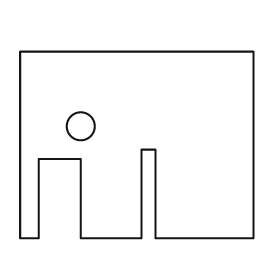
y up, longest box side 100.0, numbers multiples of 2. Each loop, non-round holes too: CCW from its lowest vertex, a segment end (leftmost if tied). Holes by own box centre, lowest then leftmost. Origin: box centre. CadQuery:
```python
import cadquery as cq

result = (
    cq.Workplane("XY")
    .moveTo(-50.0, -40.0)
    .lineTo(-42.0, -40.0)
    .lineTo(-42.0, -6.0)
    .lineTo(-24.0, -6.0)
    .lineTo(-24.0, -40.0)
    .lineTo(2.0, -40.0)
    .lineTo(2.0, -2.0)
    .lineTo(8.0, -2.0)
    .lineTo(8.0, -40.0)
    .lineTo(50.0, -40.0)
    .lineTo(50.0, 40.0)
    .lineTo(-50.0, 40.0)
    .close()
    .moveTo(-24.0, 8.0)
    .circle(6.0)
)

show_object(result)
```